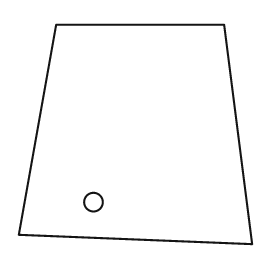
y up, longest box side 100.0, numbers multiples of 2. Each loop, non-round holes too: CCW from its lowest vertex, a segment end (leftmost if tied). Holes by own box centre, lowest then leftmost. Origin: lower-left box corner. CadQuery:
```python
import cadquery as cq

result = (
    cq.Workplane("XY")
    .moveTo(100.0, 0.0)
    .lineTo(88.0, 94.0)
    .lineTo(16.0, 94.0)
    .lineTo(0.0, 4.0)
    .close()
    .moveTo(32.0, 18.0)
    .circle(4.0)
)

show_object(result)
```